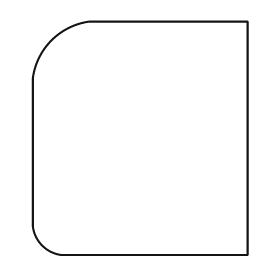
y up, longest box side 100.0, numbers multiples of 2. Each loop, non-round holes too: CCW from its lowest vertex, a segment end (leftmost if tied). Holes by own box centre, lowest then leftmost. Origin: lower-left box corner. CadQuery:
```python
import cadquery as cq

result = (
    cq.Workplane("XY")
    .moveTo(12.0, 0.0)
    .lineTo(92.0, 0.0)
    .lineTo(92.0, 100.0)
    .lineTo(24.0, 100.0)
    .threePointArc((8.0, 92.0), (0.0, 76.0))
    .lineTo(0.0, 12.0)
    .threePointArc((4.0, 4.0), (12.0, 0.0))
    .close()
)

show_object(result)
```